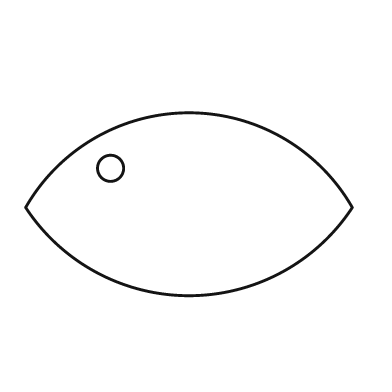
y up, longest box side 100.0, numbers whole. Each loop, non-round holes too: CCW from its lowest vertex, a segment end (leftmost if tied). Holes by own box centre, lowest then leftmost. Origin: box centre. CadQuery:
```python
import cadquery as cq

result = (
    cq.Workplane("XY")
    .moveTo(-50.0, -1.0)
    .threePointArc((0.0, -28.0), (50.0, -1.0))
    .threePointArc((0.0, 28.0), (-50.0, -1.0))
    .close()
    .moveTo(-24.0, 11.0)
    .circle(4.0)
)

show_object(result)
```